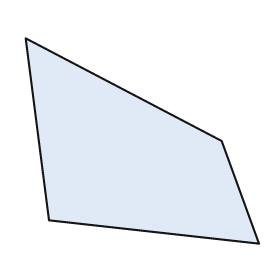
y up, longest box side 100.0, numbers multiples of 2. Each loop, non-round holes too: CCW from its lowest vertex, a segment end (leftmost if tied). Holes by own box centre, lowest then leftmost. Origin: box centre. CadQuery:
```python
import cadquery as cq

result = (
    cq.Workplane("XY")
    .moveTo(50.0, -44.0)
    .lineTo(34.0, 0.0)
    .lineTo(-50.0, 44.0)
    .lineTo(-40.0, -34.0)
    .close()
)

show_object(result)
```